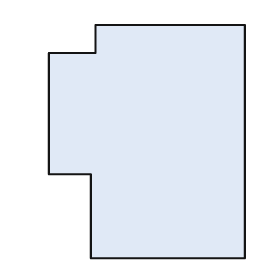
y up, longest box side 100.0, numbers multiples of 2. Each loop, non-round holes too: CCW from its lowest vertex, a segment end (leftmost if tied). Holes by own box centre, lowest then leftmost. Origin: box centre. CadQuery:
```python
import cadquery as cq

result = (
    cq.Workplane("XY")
    .moveTo(-24.0, -50.0)
    .lineTo(42.0, -50.0)
    .lineTo(42.0, 50.0)
    .lineTo(-22.0, 50.0)
    .lineTo(-22.0, 38.0)
    .lineTo(-42.0, 38.0)
    .lineTo(-42.0, -14.0)
    .lineTo(-24.0, -14.0)
    .close()
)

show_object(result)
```